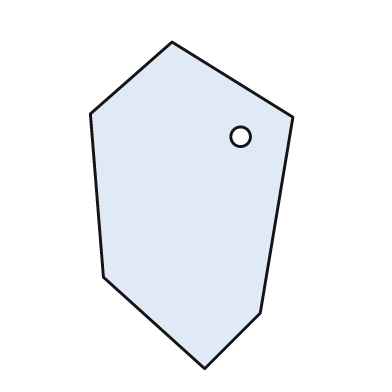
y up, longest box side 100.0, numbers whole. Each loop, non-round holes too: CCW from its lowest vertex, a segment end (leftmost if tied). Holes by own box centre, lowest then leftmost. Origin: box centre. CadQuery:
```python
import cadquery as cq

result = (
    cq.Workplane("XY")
    .moveTo(4.0, -50.0)
    .lineTo(21.0, -33.0)
    .lineTo(31.0, 27.0)
    .lineTo(-6.0, 50.0)
    .lineTo(-31.0, 28.0)
    .lineTo(-27.0, -22.0)
    .close()
    .moveTo(15.0, 21.0)
    .circle(3.0)
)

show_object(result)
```